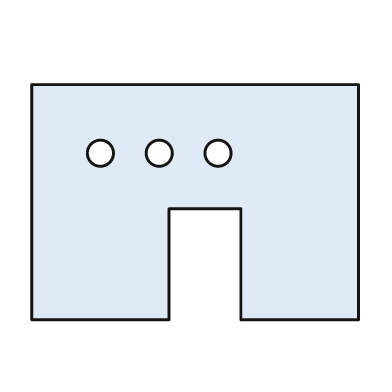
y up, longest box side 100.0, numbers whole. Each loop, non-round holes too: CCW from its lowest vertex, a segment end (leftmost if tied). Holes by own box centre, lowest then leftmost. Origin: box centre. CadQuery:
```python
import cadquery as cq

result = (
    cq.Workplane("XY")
    .moveTo(-50.0, -36.0)
    .lineTo(-8.0, -36.0)
    .lineTo(-8.0, -2.0)
    .lineTo(14.0, -2.0)
    .lineTo(14.0, -36.0)
    .lineTo(50.0, -36.0)
    .lineTo(50.0, 36.0)
    .lineTo(-50.0, 36.0)
    .close()
    .moveTo(-29.0, 15.0)
    .circle(4.0)
    .moveTo(-11.0, 15.0)
    .circle(4.0)
    .moveTo(7.0, 15.0)
    .circle(4.0)
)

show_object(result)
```